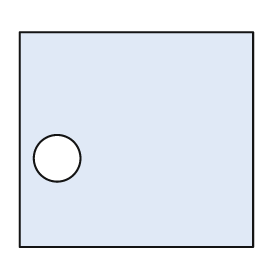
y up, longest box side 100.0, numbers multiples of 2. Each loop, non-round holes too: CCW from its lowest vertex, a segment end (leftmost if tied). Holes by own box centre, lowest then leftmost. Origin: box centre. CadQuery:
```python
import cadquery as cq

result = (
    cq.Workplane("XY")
    .moveTo(-50.0, -46.0)
    .lineTo(50.0, -46.0)
    .lineTo(50.0, 46.0)
    .lineTo(-50.0, 46.0)
    .close()
    .moveTo(-34.0, -8.0)
    .circle(10.0)
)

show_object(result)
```